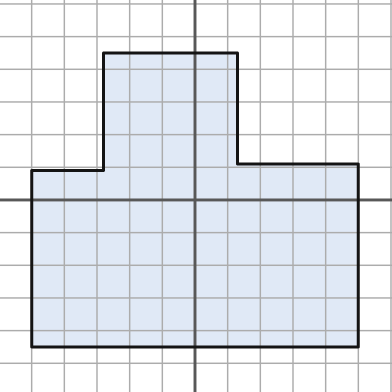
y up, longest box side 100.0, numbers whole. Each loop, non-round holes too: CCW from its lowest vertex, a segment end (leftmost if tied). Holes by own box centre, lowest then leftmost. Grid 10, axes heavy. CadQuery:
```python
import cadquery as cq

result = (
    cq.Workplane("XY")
    .moveTo(-50.0, -45.0)
    .lineTo(50.0, -45.0)
    .lineTo(50.0, 11.0)
    .lineTo(13.0, 11.0)
    .lineTo(13.0, 45.0)
    .lineTo(-28.0, 45.0)
    .lineTo(-28.0, 9.0)
    .lineTo(-50.0, 9.0)
    .close()
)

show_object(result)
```